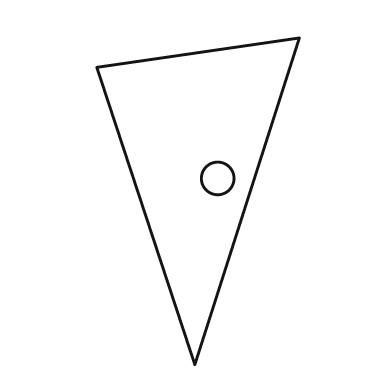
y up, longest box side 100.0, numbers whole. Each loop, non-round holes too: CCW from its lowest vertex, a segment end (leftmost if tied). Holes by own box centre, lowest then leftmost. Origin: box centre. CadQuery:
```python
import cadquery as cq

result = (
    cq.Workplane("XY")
    .moveTo(-1.0, -50.0)
    .lineTo(31.0, 50.0)
    .lineTo(-31.0, 41.0)
    .close()
    .moveTo(6.0, 7.0)
    .circle(5.0)
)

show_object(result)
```